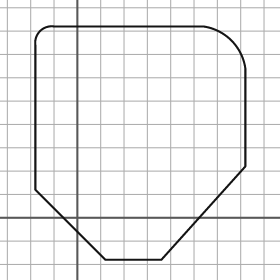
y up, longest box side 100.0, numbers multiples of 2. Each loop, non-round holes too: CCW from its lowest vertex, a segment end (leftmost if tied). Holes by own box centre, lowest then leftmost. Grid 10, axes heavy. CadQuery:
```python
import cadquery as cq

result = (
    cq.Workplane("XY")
    .moveTo(12.0, -18.0)
    .lineTo(36.0, -18.0)
    .lineTo(72.0, 22.0)
    .lineTo(72.0, 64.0)
    .threePointArc((66.0, 76.0), (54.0, 82.0))
    .lineTo(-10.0, 82.0)
    .threePointArc((-16.0, 80.0), (-18.0, 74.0))
    .lineTo(-18.0, 12.0)
    .close()
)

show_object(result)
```